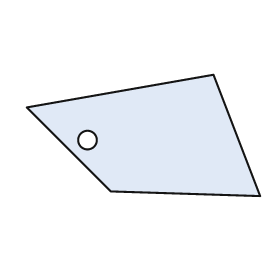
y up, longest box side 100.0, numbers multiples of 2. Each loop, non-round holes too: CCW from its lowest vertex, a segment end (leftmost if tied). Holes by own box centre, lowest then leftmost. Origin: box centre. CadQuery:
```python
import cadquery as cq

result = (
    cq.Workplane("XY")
    .moveTo(50.0, -26.0)
    .lineTo(30.0, 26.0)
    .lineTo(-50.0, 12.0)
    .lineTo(-14.0, -24.0)
    .close()
    .moveTo(-24.0, -2.0)
    .circle(4.0)
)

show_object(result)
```